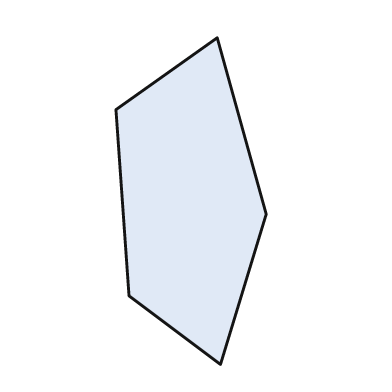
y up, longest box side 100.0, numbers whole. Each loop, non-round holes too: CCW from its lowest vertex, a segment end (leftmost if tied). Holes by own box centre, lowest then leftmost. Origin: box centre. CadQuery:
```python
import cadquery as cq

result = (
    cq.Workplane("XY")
    .moveTo(9.0, -50.0)
    .lineTo(23.0, -4.0)
    .lineTo(8.0, 50.0)
    .lineTo(-23.0, 28.0)
    .lineTo(-19.0, -29.0)
    .close()
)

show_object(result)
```